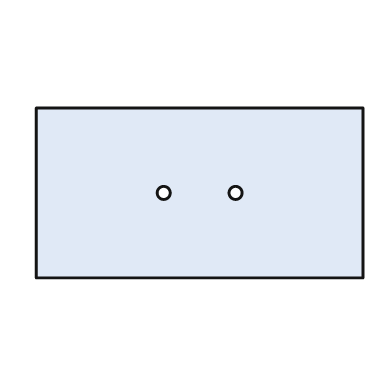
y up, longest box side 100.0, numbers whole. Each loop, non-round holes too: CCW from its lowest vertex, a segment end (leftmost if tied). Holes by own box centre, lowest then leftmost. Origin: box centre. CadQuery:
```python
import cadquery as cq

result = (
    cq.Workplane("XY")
    .moveTo(-50.0, -26.0)
    .lineTo(50.0, -26.0)
    .lineTo(50.0, 26.0)
    .lineTo(-50.0, 26.0)
    .close()
    .moveTo(-11.0, 0.0)
    .circle(2.0)
    .moveTo(11.0, 0.0)
    .circle(2.0)
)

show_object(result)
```